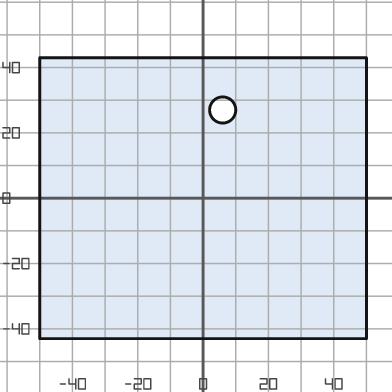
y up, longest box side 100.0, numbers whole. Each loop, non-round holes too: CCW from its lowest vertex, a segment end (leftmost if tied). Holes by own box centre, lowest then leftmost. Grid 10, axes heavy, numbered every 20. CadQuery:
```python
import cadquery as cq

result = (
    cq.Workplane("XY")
    .moveTo(-50.0, -43.0)
    .lineTo(50.0, -43.0)
    .lineTo(50.0, 43.0)
    .lineTo(-50.0, 43.0)
    .close()
    .moveTo(6.0, 27.0)
    .circle(4.0)
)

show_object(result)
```